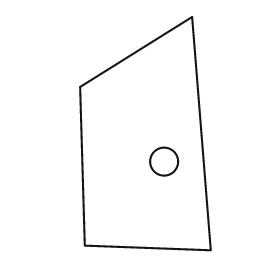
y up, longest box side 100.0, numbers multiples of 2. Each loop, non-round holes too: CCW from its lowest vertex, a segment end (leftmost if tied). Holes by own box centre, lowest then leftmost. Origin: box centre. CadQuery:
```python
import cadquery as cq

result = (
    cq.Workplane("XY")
    .moveTo(28.0, -50.0)
    .lineTo(20.0, 50.0)
    .lineTo(-28.0, 20.0)
    .lineTo(-26.0, -48.0)
    .close()
    .moveTo(8.0, -12.0)
    .circle(6.0)
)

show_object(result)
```